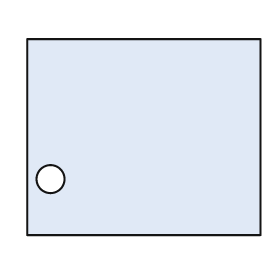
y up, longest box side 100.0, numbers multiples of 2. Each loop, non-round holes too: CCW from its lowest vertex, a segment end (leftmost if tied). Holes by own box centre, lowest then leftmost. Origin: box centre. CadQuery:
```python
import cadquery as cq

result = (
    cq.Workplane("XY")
    .moveTo(-50.0, -42.0)
    .lineTo(50.0, -42.0)
    .lineTo(50.0, 42.0)
    .lineTo(-50.0, 42.0)
    .close()
    .moveTo(-40.0, -18.0)
    .circle(6.0)
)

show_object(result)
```